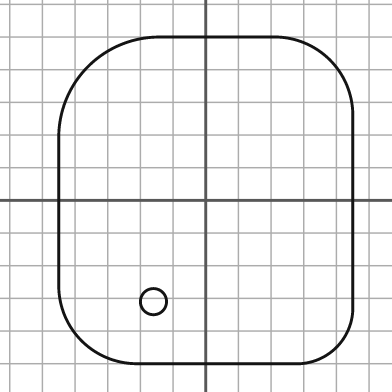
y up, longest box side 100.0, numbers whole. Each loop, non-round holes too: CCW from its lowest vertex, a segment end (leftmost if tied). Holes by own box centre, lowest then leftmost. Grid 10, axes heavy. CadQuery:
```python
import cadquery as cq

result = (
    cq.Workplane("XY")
    .moveTo(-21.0, -50.0)
    .lineTo(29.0, -50.0)
    .threePointArc((40.0, -45.0), (45.0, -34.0))
    .lineTo(45.0, 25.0)
    .threePointArc((38.0, 43.0), (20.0, 50.0))
    .lineTo(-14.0, 50.0)
    .threePointArc((-36.0, 41.0), (-45.0, 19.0))
    .lineTo(-45.0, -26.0)
    .threePointArc((-38.0, -43.0), (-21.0, -50.0))
    .close()
    .moveTo(-16.0, -31.0)
    .circle(4.0)
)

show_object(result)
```